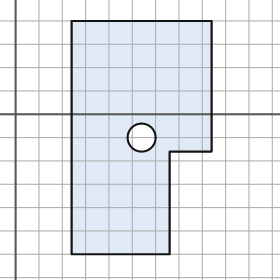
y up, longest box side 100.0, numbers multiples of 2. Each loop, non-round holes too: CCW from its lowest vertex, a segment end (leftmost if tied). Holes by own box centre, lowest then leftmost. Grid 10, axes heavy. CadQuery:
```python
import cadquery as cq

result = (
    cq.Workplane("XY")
    .moveTo(24.0, -60.0)
    .lineTo(66.0, -60.0)
    .lineTo(66.0, -16.0)
    .lineTo(84.0, -16.0)
    .lineTo(84.0, 40.0)
    .lineTo(24.0, 40.0)
    .close()
    .moveTo(54.0, -10.0)
    .circle(6.0)
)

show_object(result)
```